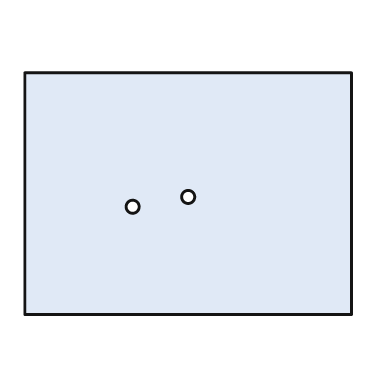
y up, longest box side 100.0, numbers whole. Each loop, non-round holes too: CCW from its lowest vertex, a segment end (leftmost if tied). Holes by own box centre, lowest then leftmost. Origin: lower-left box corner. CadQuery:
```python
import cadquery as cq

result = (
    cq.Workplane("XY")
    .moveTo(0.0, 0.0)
    .lineTo(100.0, 0.0)
    .lineTo(100.0, 74.0)
    .lineTo(0.0, 74.0)
    .close()
    .moveTo(33.0, 33.0)
    .circle(2.0)
    .moveTo(50.0, 36.0)
    .circle(2.0)
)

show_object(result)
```